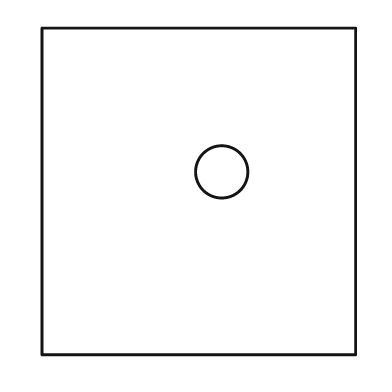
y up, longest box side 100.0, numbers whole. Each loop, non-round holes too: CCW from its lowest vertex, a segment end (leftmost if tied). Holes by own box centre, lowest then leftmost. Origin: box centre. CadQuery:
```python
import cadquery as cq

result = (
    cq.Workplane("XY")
    .moveTo(-48.0, -50.0)
    .lineTo(48.0, -50.0)
    .lineTo(48.0, 50.0)
    .lineTo(-48.0, 50.0)
    .close()
    .moveTo(7.0, 6.0)
    .circle(8.0)
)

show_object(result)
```